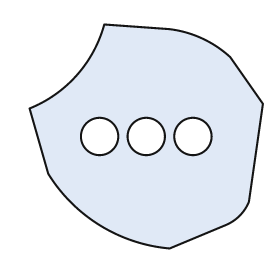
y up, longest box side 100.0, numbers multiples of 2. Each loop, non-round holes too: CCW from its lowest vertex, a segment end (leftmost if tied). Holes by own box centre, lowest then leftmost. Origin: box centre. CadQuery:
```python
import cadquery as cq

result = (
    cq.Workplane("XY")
    .moveTo(10.0, -48.0)
    .lineTo(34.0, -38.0)
    .threePointArc((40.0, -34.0), (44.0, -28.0))
    .lineTo(50.0, 14.0)
    .lineTo(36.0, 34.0)
    .threePointArc((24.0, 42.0), (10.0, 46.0))
    .lineTo(-18.0, 48.0)
    .threePointArc((-30.0, 26.0), (-50.0, 12.0))
    .lineTo(-42.0, -16.0)
    .threePointArc((-20.0, -38.0), (10.0, -48.0))
    .close()
    .moveTo(-20.0, 0.0)
    .circle(8.0)
    .moveTo(0.0, 0.0)
    .circle(8.0)
    .moveTo(20.0, 0.0)
    .circle(8.0)
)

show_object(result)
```